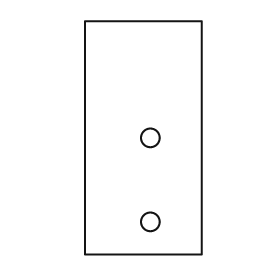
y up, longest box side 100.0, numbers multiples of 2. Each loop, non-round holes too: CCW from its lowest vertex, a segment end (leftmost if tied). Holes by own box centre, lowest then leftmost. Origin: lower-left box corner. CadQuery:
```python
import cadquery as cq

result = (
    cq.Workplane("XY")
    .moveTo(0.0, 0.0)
    .lineTo(50.0, 0.0)
    .lineTo(50.0, 100.0)
    .lineTo(0.0, 100.0)
    .close()
    .moveTo(28.0, 14.0)
    .circle(4.0)
    .moveTo(28.0, 50.0)
    .circle(4.0)
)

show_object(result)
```